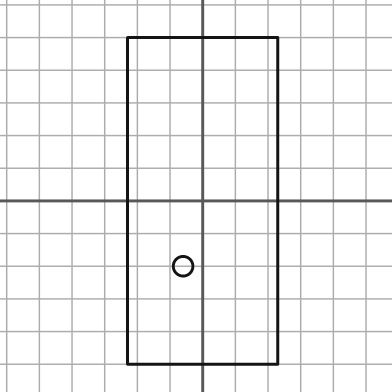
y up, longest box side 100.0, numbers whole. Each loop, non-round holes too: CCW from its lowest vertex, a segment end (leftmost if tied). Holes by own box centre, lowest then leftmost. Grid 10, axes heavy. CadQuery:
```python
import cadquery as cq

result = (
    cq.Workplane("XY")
    .moveTo(-23.0, -50.0)
    .lineTo(23.0, -50.0)
    .lineTo(23.0, 50.0)
    .lineTo(-23.0, 50.0)
    .close()
    .moveTo(-6.0, -20.0)
    .circle(3.0)
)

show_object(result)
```